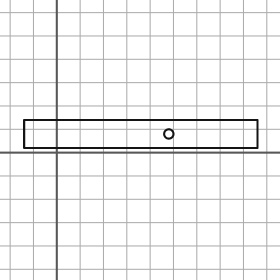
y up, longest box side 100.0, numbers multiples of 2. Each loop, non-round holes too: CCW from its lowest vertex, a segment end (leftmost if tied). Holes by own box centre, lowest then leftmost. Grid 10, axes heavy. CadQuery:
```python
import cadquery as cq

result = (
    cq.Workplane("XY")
    .moveTo(-14.0, 2.0)
    .lineTo(86.0, 2.0)
    .lineTo(86.0, 14.0)
    .lineTo(-14.0, 14.0)
    .close()
    .moveTo(48.0, 8.0)
    .circle(2.0)
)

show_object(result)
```